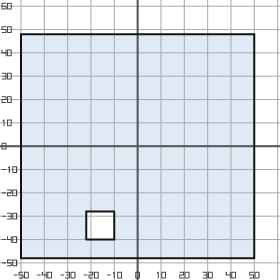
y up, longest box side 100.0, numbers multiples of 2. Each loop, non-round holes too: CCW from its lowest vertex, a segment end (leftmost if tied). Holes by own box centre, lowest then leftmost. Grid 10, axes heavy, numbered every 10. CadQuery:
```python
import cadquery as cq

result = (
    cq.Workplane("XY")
    .moveTo(-50.0, -48.0)
    .lineTo(50.0, -48.0)
    .lineTo(50.0, 48.0)
    .lineTo(-50.0, 48.0)
    .close()
    .moveTo(-22.0, -40.0)
    .lineTo(-10.0, -40.0)
    .lineTo(-10.0, -28.0)
    .lineTo(-22.0, -28.0)
    .close()
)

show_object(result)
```